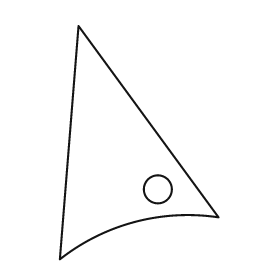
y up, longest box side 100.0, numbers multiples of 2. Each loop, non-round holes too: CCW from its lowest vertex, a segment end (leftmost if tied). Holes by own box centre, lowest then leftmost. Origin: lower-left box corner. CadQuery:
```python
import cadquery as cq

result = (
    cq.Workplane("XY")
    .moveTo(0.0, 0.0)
    .threePointArc((32.0, 16.0), (68.0, 18.0))
    .lineTo(8.0, 100.0)
    .close()
    .moveTo(42.0, 30.0)
    .circle(6.0)
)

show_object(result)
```